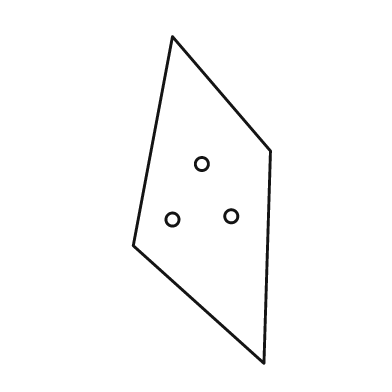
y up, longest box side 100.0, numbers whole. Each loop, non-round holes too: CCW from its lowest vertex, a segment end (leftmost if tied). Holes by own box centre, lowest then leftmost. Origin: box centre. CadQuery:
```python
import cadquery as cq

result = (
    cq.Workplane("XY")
    .moveTo(19.0, -50.0)
    .lineTo(21.0, 15.0)
    .lineTo(-9.0, 50.0)
    .lineTo(-21.0, -14.0)
    .close()
    .moveTo(-9.0, -6.0)
    .circle(2.0)
    .moveTo(9.0, -5.0)
    .circle(2.0)
    .moveTo(0.0, 11.0)
    .circle(2.0)
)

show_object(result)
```